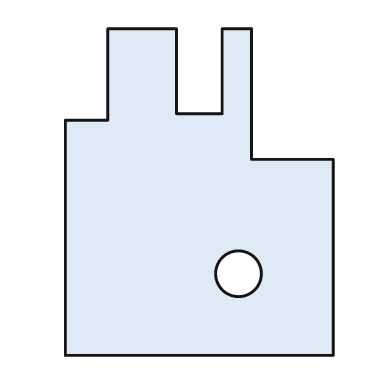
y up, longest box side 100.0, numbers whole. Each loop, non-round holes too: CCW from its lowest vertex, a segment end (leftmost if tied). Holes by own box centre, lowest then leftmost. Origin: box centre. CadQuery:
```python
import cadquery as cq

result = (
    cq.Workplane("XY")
    .moveTo(-41.0, -50.0)
    .lineTo(41.0, -50.0)
    .lineTo(41.0, 10.0)
    .lineTo(16.0, 10.0)
    .lineTo(16.0, 50.0)
    .lineTo(7.0, 50.0)
    .lineTo(7.0, 24.0)
    .lineTo(-7.0, 24.0)
    .lineTo(-7.0, 50.0)
    .lineTo(-28.0, 50.0)
    .lineTo(-28.0, 22.0)
    .lineTo(-41.0, 22.0)
    .close()
    .moveTo(12.0, -25.0)
    .circle(7.0)
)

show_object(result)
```